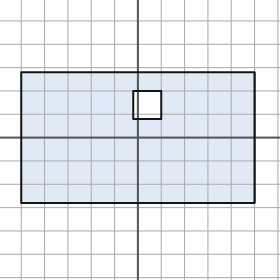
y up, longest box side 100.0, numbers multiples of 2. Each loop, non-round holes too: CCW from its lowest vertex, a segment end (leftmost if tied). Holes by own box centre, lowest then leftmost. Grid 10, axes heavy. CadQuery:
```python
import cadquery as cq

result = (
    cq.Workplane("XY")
    .moveTo(-50.0, -28.0)
    .lineTo(50.0, -28.0)
    .lineTo(50.0, 28.0)
    .lineTo(-50.0, 28.0)
    .close()
    .moveTo(-2.0, 8.0)
    .lineTo(10.0, 8.0)
    .lineTo(10.0, 20.0)
    .lineTo(-2.0, 20.0)
    .close()
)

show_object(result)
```